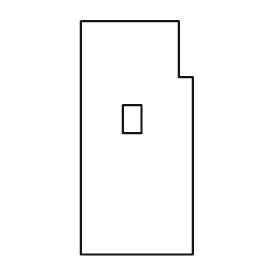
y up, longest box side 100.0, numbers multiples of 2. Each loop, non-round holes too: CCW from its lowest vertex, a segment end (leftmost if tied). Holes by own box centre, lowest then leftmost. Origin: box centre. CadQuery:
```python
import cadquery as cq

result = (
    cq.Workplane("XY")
    .moveTo(-24.0, -50.0)
    .lineTo(24.0, -50.0)
    .lineTo(24.0, 26.0)
    .lineTo(18.0, 26.0)
    .lineTo(18.0, 50.0)
    .lineTo(-24.0, 50.0)
    .close()
    .moveTo(-6.0, 2.0)
    .lineTo(2.0, 2.0)
    .lineTo(2.0, 14.0)
    .lineTo(-6.0, 14.0)
    .close()
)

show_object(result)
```